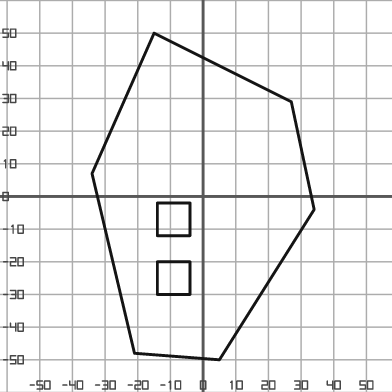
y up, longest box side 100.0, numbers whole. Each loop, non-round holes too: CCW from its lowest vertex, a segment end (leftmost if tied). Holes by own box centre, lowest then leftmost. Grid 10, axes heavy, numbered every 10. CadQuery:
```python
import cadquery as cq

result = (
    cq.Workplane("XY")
    .moveTo(5.0, -50.0)
    .lineTo(34.0, -4.0)
    .lineTo(27.0, 29.0)
    .lineTo(-15.0, 50.0)
    .lineTo(-34.0, 7.0)
    .lineTo(-21.0, -48.0)
    .close()
    .moveTo(-14.0, -30.0)
    .lineTo(-4.0, -30.0)
    .lineTo(-4.0, -20.0)
    .lineTo(-14.0, -20.0)
    .close()
    .moveTo(-14.0, -12.0)
    .lineTo(-4.0, -12.0)
    .lineTo(-4.0, -2.0)
    .lineTo(-14.0, -2.0)
    .close()
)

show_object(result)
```